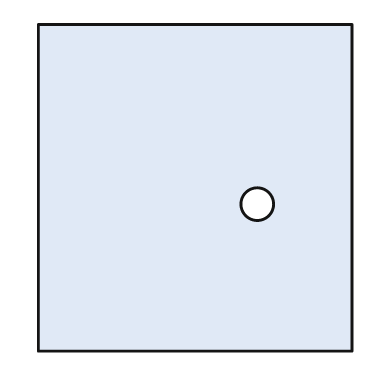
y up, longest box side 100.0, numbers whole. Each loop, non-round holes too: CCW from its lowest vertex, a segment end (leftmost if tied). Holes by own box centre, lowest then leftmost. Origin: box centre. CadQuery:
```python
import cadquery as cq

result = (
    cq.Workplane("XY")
    .moveTo(-48.0, -50.0)
    .lineTo(48.0, -50.0)
    .lineTo(48.0, 50.0)
    .lineTo(-48.0, 50.0)
    .close()
    .moveTo(19.0, -5.0)
    .circle(5.0)
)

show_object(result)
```